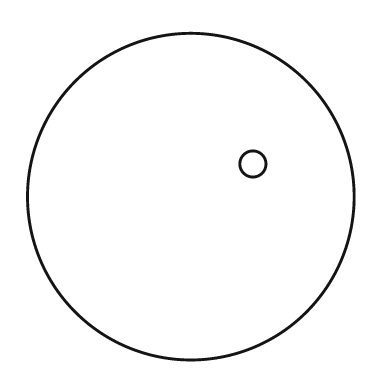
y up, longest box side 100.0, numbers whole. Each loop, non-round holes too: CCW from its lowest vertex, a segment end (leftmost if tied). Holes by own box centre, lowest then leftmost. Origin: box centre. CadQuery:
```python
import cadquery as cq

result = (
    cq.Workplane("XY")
    .moveTo(0.0, 0.0)
    .circle(50.0)
    .moveTo(19.0, 10.0)
    .circle(4.0)
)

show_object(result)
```